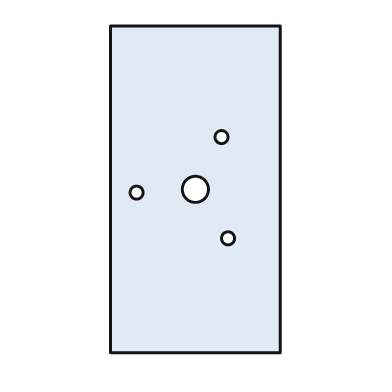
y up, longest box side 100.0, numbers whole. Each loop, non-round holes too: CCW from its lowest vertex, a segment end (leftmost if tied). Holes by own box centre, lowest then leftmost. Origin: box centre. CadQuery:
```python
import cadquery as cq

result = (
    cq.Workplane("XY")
    .moveTo(-26.0, -50.0)
    .lineTo(26.0, -50.0)
    .lineTo(26.0, 50.0)
    .lineTo(-26.0, 50.0)
    .close()
    .moveTo(10.0, -15.0)
    .circle(2.0)
    .moveTo(-18.0, -1.0)
    .circle(2.0)
    .moveTo(0.0, 0.0)
    .circle(4.0)
    .moveTo(8.0, 16.0)
    .circle(2.0)
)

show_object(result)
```